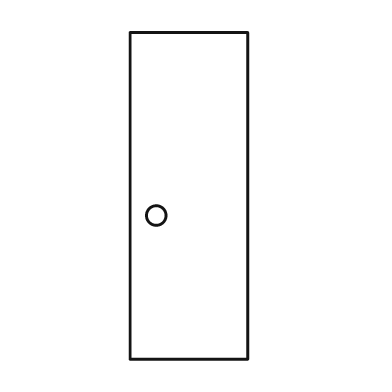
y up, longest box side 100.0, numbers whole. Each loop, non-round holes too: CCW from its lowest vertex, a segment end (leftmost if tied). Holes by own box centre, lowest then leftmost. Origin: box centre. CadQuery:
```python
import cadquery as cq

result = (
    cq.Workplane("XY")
    .moveTo(-18.0, -50.0)
    .lineTo(18.0, -50.0)
    .lineTo(18.0, 50.0)
    .lineTo(-18.0, 50.0)
    .close()
    .moveTo(-10.0, -6.0)
    .circle(3.0)
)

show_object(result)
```